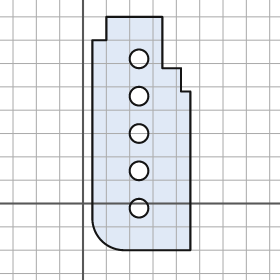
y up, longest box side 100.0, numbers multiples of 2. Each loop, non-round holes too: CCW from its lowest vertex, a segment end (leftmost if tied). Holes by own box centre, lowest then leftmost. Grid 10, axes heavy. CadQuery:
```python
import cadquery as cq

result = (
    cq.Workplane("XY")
    .moveTo(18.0, -20.0)
    .lineTo(46.0, -20.0)
    .lineTo(46.0, 48.0)
    .lineTo(42.0, 48.0)
    .lineTo(42.0, 58.0)
    .lineTo(34.0, 58.0)
    .lineTo(34.0, 80.0)
    .lineTo(10.0, 80.0)
    .lineTo(10.0, 70.0)
    .lineTo(4.0, 70.0)
    .lineTo(4.0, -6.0)
    .threePointArc((8.0, -16.0), (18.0, -20.0))
    .close()
    .moveTo(24.0, -2.0)
    .circle(4.0)
    .moveTo(24.0, 14.0)
    .circle(4.0)
    .moveTo(24.0, 30.0)
    .circle(4.0)
    .moveTo(24.0, 46.0)
    .circle(4.0)
    .moveTo(24.0, 62.0)
    .circle(4.0)
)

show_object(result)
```